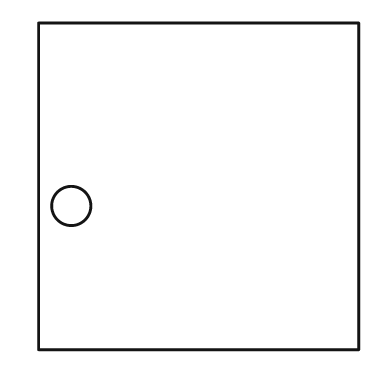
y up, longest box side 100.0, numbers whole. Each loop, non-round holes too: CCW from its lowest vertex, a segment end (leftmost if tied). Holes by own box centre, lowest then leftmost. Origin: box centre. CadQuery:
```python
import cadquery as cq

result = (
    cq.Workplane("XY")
    .moveTo(-49.0, -50.0)
    .lineTo(49.0, -50.0)
    .lineTo(49.0, 50.0)
    .lineTo(-49.0, 50.0)
    .close()
    .moveTo(-39.0, -6.0)
    .circle(6.0)
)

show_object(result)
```